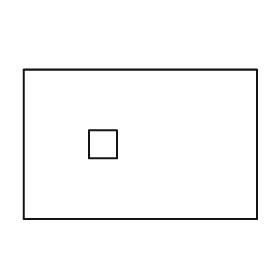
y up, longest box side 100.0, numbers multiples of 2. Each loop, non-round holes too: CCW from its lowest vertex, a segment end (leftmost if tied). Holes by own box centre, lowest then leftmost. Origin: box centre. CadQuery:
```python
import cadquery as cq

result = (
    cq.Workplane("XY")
    .moveTo(-50.0, -32.0)
    .lineTo(50.0, -32.0)
    .lineTo(50.0, 32.0)
    .lineTo(-50.0, 32.0)
    .close()
    .moveTo(-22.0, -6.0)
    .lineTo(-10.0, -6.0)
    .lineTo(-10.0, 6.0)
    .lineTo(-22.0, 6.0)
    .close()
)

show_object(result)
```